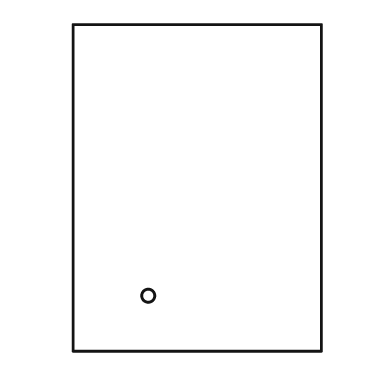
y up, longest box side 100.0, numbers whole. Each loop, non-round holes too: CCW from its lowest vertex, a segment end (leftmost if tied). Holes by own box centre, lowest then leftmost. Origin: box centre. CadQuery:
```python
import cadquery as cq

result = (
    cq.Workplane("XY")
    .moveTo(-38.0, -50.0)
    .lineTo(38.0, -50.0)
    .lineTo(38.0, 50.0)
    .lineTo(-38.0, 50.0)
    .close()
    .moveTo(-15.0, -33.0)
    .circle(2.0)
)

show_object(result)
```